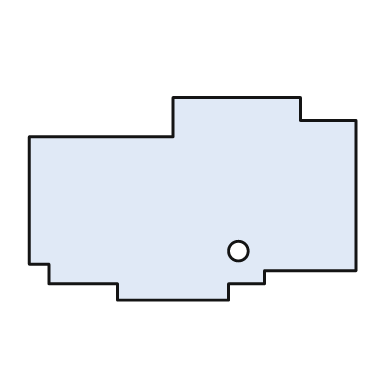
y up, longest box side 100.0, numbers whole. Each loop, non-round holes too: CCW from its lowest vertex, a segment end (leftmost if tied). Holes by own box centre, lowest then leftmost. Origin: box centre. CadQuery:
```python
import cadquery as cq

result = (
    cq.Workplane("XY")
    .moveTo(-23.0, -31.0)
    .lineTo(11.0, -31.0)
    .lineTo(11.0, -26.0)
    .lineTo(22.0, -26.0)
    .lineTo(22.0, -22.0)
    .lineTo(50.0, -22.0)
    .lineTo(50.0, 24.0)
    .lineTo(33.0, 24.0)
    .lineTo(33.0, 31.0)
    .lineTo(-6.0, 31.0)
    .lineTo(-6.0, 19.0)
    .lineTo(-50.0, 19.0)
    .lineTo(-50.0, -20.0)
    .lineTo(-44.0, -20.0)
    .lineTo(-44.0, -26.0)
    .lineTo(-23.0, -26.0)
    .close()
    .moveTo(14.0, -16.0)
    .circle(3.0)
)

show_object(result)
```